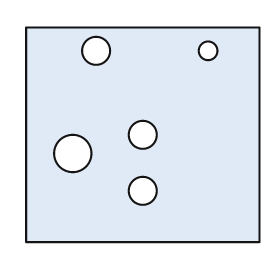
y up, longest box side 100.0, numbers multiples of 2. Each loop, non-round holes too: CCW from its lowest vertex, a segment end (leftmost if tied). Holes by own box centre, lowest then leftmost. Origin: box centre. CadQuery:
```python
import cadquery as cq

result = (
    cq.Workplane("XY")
    .moveTo(-50.0, -46.0)
    .lineTo(50.0, -46.0)
    .lineTo(50.0, 46.0)
    .lineTo(-50.0, 46.0)
    .close()
    .moveTo(0.0, -24.0)
    .circle(6.0)
    .moveTo(-30.0, -8.0)
    .circle(8.0)
    .moveTo(0.0, 0.0)
    .circle(6.0)
    .moveTo(-20.0, 36.0)
    .circle(6.0)
    .moveTo(28.0, 36.0)
    .circle(4.0)
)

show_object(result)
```